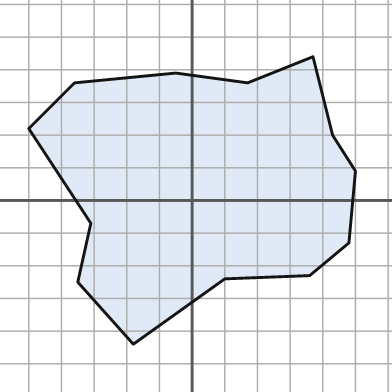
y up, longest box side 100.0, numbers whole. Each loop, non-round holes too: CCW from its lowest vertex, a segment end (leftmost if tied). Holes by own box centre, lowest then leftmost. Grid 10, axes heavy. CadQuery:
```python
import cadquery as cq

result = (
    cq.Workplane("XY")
    .moveTo(-18.0, -44.0)
    .lineTo(10.0, -24.0)
    .lineTo(36.0, -23.0)
    .lineTo(48.0, -13.0)
    .lineTo(50.0, 9.0)
    .lineTo(43.0, 20.0)
    .lineTo(37.0, 44.0)
    .lineTo(17.0, 36.0)
    .lineTo(-5.0, 39.0)
    .lineTo(-36.0, 36.0)
    .lineTo(-50.0, 22.0)
    .lineTo(-31.0, -7.0)
    .lineTo(-35.0, -25.0)
    .close()
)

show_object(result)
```